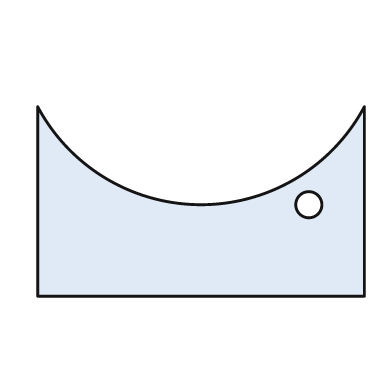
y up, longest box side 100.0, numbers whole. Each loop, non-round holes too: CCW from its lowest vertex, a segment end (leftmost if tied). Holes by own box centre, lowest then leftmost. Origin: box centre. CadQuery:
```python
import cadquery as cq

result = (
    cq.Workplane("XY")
    .moveTo(-50.0, -29.0)
    .lineTo(50.0, -29.0)
    .lineTo(50.0, 29.0)
    .threePointArc((0.0, -1.0), (-50.0, 29.0))
    .close()
    .moveTo(33.0, -1.0)
    .circle(4.0)
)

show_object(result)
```